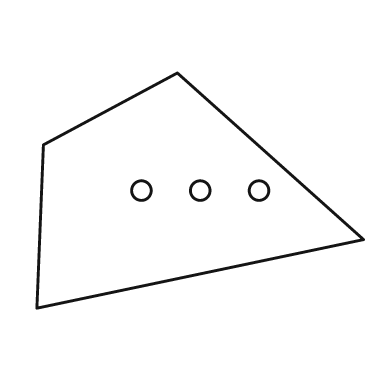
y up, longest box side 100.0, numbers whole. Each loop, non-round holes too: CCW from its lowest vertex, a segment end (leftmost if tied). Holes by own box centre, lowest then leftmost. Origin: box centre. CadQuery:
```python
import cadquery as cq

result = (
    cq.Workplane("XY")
    .moveTo(-50.0, -36.0)
    .lineTo(50.0, -15.0)
    .lineTo(-7.0, 36.0)
    .lineTo(-48.0, 14.0)
    .close()
    .moveTo(-18.0, 0.0)
    .circle(3.0)
    .moveTo(0.0, 0.0)
    .circle(3.0)
    .moveTo(18.0, 0.0)
    .circle(3.0)
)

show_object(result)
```